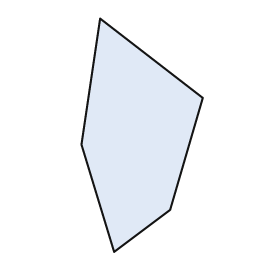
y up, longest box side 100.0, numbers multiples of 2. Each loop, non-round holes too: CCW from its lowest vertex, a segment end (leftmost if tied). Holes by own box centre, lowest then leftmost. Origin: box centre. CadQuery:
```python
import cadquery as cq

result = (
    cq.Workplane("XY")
    .moveTo(-12.0, -50.0)
    .lineTo(12.0, -32.0)
    .lineTo(26.0, 16.0)
    .lineTo(-18.0, 50.0)
    .lineTo(-26.0, -4.0)
    .close()
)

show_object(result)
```